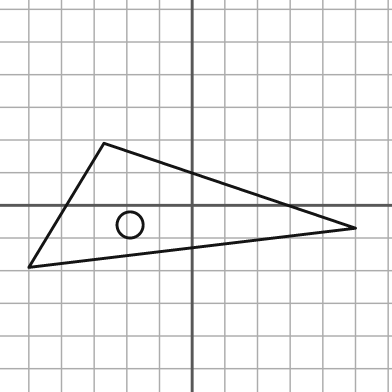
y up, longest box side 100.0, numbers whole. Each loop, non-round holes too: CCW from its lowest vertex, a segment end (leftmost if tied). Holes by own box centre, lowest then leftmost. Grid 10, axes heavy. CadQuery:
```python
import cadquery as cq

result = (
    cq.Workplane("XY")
    .moveTo(-50.0, -19.0)
    .lineTo(50.0, -7.0)
    .lineTo(-27.0, 19.0)
    .close()
    .moveTo(-19.0, -6.0)
    .circle(4.0)
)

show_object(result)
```